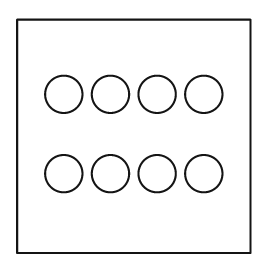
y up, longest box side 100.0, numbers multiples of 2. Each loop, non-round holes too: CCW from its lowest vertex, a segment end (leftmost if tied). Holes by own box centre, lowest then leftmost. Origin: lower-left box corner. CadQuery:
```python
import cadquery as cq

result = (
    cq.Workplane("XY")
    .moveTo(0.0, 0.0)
    .lineTo(100.0, 0.0)
    .lineTo(100.0, 100.0)
    .lineTo(0.0, 100.0)
    .close()
    .moveTo(20.0, 34.0)
    .circle(8.0)
    .moveTo(40.0, 34.0)
    .circle(8.0)
    .moveTo(60.0, 34.0)
    .circle(8.0)
    .moveTo(80.0, 34.0)
    .circle(8.0)
    .moveTo(20.0, 68.0)
    .circle(8.0)
    .moveTo(40.0, 68.0)
    .circle(8.0)
    .moveTo(60.0, 68.0)
    .circle(8.0)
    .moveTo(80.0, 68.0)
    .circle(8.0)
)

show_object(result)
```